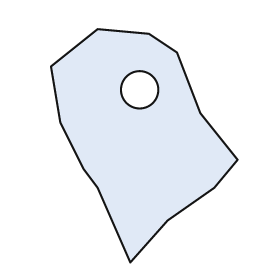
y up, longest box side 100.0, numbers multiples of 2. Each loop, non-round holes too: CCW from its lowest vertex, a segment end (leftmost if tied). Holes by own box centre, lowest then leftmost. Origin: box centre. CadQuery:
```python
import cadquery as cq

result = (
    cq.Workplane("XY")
    .moveTo(-6.0, -50.0)
    .lineTo(10.0, -32.0)
    .lineTo(30.0, -18.0)
    .lineTo(40.0, -6.0)
    .lineTo(24.0, 14.0)
    .lineTo(14.0, 40.0)
    .lineTo(2.0, 48.0)
    .lineTo(-20.0, 50.0)
    .lineTo(-40.0, 34.0)
    .lineTo(-36.0, 10.0)
    .lineTo(-26.0, -10.0)
    .lineTo(-20.0, -18.0)
    .close()
    .moveTo(-2.0, 24.0)
    .circle(8.0)
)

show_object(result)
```